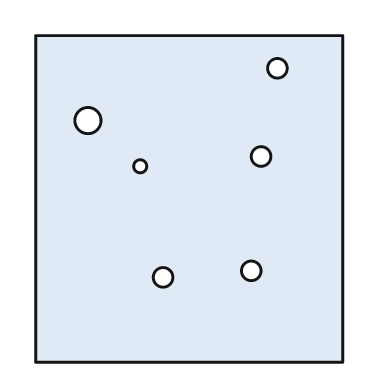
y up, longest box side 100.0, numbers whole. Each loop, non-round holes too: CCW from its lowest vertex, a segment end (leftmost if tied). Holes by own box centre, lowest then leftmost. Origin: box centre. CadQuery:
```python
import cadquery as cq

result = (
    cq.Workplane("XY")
    .moveTo(-47.0, -50.0)
    .lineTo(47.0, -50.0)
    .lineTo(47.0, 50.0)
    .lineTo(-47.0, 50.0)
    .close()
    .moveTo(-8.0, -24.0)
    .circle(3.0)
    .moveTo(19.0, -22.0)
    .circle(3.0)
    .moveTo(-15.0, 10.0)
    .circle(2.0)
    .moveTo(22.0, 13.0)
    .circle(3.0)
    .moveTo(-31.0, 24.0)
    .circle(4.0)
    .moveTo(27.0, 40.0)
    .circle(3.0)
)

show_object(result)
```